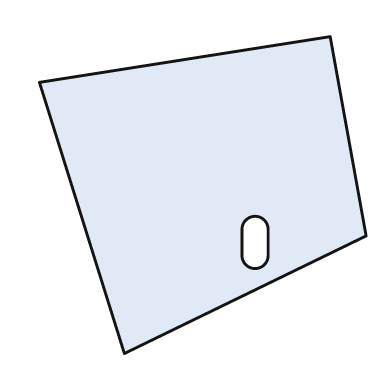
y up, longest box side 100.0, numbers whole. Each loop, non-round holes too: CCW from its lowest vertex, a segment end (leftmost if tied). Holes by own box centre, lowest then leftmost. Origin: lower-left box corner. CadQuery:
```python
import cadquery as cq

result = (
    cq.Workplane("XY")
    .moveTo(26.0, 0.0)
    .lineTo(100.0, 36.0)
    .lineTo(89.0, 97.0)
    .lineTo(0.0, 83.0)
    .close()
    .moveTo(62.0, 30.0)
    .threePointArc((66.0, 26.0), (70.0, 30.0))
    .lineTo(70.0, 38.0)
    .threePointArc((66.0, 42.0), (62.0, 38.0))
    .close()
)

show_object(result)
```